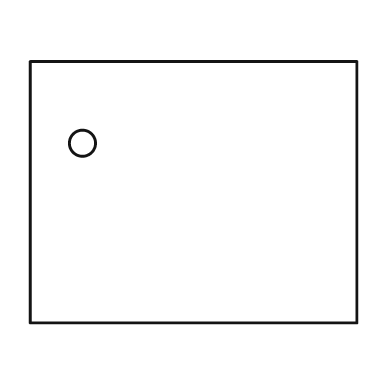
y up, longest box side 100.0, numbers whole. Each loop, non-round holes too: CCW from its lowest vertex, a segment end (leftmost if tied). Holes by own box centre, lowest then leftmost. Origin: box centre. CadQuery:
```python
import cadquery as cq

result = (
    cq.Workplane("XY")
    .moveTo(-50.0, -40.0)
    .lineTo(50.0, -40.0)
    .lineTo(50.0, 40.0)
    .lineTo(-50.0, 40.0)
    .close()
    .moveTo(-34.0, 15.0)
    .circle(4.0)
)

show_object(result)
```